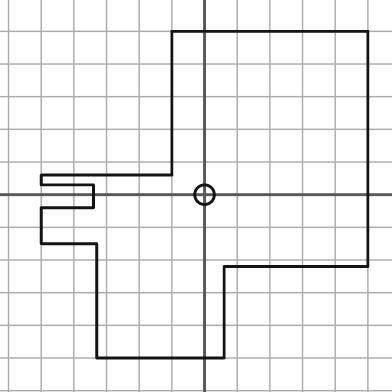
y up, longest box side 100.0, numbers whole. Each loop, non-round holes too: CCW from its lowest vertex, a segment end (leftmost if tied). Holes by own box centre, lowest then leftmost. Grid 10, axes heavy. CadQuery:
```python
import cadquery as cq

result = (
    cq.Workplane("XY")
    .moveTo(-33.0, -50.0)
    .lineTo(6.0, -50.0)
    .lineTo(6.0, -22.0)
    .lineTo(50.0, -22.0)
    .lineTo(50.0, 50.0)
    .lineTo(-10.0, 50.0)
    .lineTo(-10.0, 6.0)
    .lineTo(-50.0, 6.0)
    .lineTo(-50.0, 3.0)
    .lineTo(-34.0, 3.0)
    .lineTo(-34.0, -4.0)
    .lineTo(-50.0, -4.0)
    .lineTo(-50.0, -15.0)
    .lineTo(-33.0, -15.0)
    .close()
    .moveTo(0.0, 0.0)
    .circle(3.0)
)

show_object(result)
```